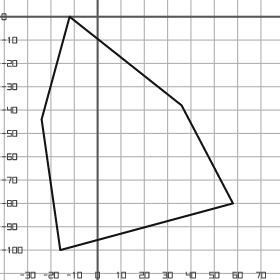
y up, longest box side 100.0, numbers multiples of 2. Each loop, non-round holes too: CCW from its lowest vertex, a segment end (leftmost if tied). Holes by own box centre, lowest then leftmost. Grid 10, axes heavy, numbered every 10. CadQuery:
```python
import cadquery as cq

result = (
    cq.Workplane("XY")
    .moveTo(-16.0, -100.0)
    .lineTo(58.0, -80.0)
    .lineTo(36.0, -38.0)
    .lineTo(-12.0, 0.0)
    .lineTo(-24.0, -44.0)
    .close()
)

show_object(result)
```